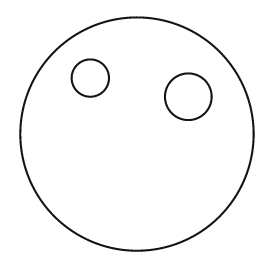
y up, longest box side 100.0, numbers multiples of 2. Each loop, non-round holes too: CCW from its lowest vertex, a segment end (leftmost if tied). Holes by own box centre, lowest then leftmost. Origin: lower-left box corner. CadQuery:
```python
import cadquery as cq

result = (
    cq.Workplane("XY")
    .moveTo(50.0, 50.0)
    .circle(50.0)
    .moveTo(72.0, 66.0)
    .circle(10.0)
    .moveTo(30.0, 74.0)
    .circle(8.0)
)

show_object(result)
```